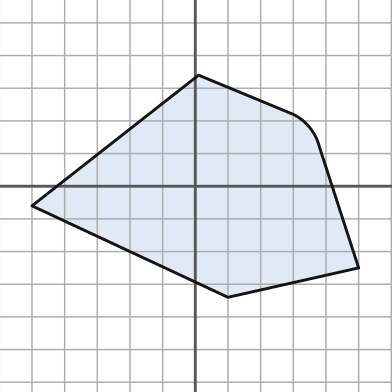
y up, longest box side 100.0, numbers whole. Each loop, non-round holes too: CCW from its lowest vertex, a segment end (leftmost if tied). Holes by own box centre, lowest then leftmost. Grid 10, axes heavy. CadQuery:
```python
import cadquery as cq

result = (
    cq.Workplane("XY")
    .moveTo(10.0, -34.0)
    .lineTo(50.0, -25.0)
    .lineTo(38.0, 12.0)
    .threePointArc((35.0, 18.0), (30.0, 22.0))
    .lineTo(1.0, 34.0)
    .lineTo(-50.0, -6.0)
    .close()
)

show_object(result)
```